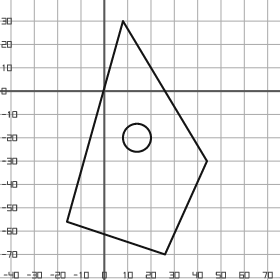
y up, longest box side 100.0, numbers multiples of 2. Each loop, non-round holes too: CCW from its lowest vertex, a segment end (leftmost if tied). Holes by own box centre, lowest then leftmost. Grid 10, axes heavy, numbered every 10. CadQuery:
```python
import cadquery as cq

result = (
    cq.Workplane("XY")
    .moveTo(26.0, -70.0)
    .lineTo(44.0, -30.0)
    .lineTo(8.0, 30.0)
    .lineTo(-16.0, -56.0)
    .close()
    .moveTo(14.0, -20.0)
    .circle(6.0)
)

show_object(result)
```